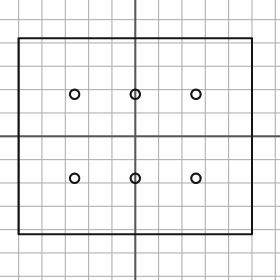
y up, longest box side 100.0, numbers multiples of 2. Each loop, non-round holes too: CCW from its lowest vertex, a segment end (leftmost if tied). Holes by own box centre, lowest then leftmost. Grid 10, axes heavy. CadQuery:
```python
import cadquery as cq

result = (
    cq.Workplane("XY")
    .moveTo(-50.0, -42.0)
    .lineTo(50.0, -42.0)
    .lineTo(50.0, 42.0)
    .lineTo(-50.0, 42.0)
    .close()
    .moveTo(-26.0, -18.0)
    .circle(2.0)
    .moveTo(0.0, -18.0)
    .circle(2.0)
    .moveTo(26.0, -18.0)
    .circle(2.0)
    .moveTo(-26.0, 18.0)
    .circle(2.0)
    .moveTo(0.0, 18.0)
    .circle(2.0)
    .moveTo(26.0, 18.0)
    .circle(2.0)
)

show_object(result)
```